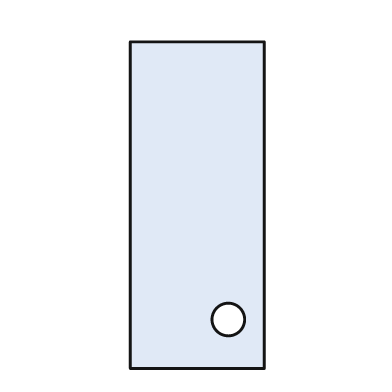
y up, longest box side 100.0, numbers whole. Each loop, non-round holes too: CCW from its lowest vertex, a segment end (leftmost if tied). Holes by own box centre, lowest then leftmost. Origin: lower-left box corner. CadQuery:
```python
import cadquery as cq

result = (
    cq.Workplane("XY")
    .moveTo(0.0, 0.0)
    .lineTo(41.0, 0.0)
    .lineTo(41.0, 100.0)
    .lineTo(0.0, 100.0)
    .close()
    .moveTo(30.0, 15.0)
    .circle(5.0)
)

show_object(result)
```